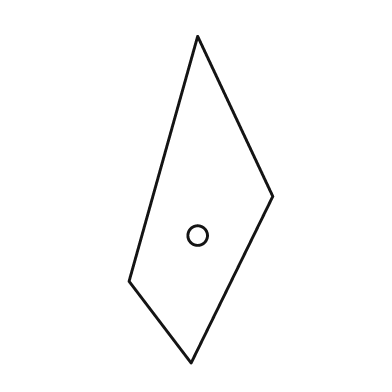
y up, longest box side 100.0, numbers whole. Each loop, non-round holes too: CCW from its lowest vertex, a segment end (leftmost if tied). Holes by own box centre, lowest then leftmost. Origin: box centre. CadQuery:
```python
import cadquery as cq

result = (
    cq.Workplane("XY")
    .moveTo(-3.0, -50.0)
    .lineTo(22.0, 1.0)
    .lineTo(-1.0, 50.0)
    .lineTo(-22.0, -25.0)
    .close()
    .moveTo(-1.0, -11.0)
    .circle(3.0)
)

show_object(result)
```